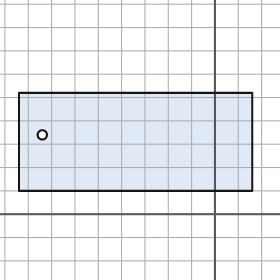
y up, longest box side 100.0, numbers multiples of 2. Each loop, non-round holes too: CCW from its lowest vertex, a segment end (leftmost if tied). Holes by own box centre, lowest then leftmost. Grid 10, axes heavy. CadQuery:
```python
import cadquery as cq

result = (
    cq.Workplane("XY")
    .moveTo(-84.0, 10.0)
    .lineTo(16.0, 10.0)
    .lineTo(16.0, 52.0)
    .lineTo(-84.0, 52.0)
    .close()
    .moveTo(-74.0, 34.0)
    .circle(2.0)
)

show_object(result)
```